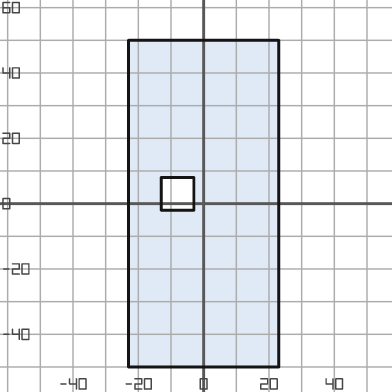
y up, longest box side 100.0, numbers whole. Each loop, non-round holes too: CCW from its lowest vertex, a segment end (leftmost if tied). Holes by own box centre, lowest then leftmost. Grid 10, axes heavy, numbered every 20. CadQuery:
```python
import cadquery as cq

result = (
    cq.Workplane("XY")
    .moveTo(-23.0, -50.0)
    .lineTo(23.0, -50.0)
    .lineTo(23.0, 50.0)
    .lineTo(-23.0, 50.0)
    .close()
    .moveTo(-13.0, -2.0)
    .lineTo(-3.0, -2.0)
    .lineTo(-3.0, 8.0)
    .lineTo(-13.0, 8.0)
    .close()
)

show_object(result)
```